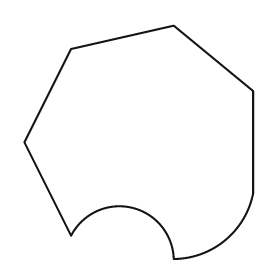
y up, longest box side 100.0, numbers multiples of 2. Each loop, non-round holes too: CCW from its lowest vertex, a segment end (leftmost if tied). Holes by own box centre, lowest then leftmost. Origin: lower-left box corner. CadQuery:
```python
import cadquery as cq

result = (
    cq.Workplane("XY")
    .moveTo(64.0, 0.0)
    .threePointArc((86.0, 8.0), (98.0, 28.0))
    .lineTo(98.0, 72.0)
    .lineTo(64.0, 100.0)
    .lineTo(20.0, 90.0)
    .lineTo(0.0, 50.0)
    .lineTo(20.0, 10.0)
    .threePointArc((46.0, 22.0), (64.0, 0.0))
    .close()
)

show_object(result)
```